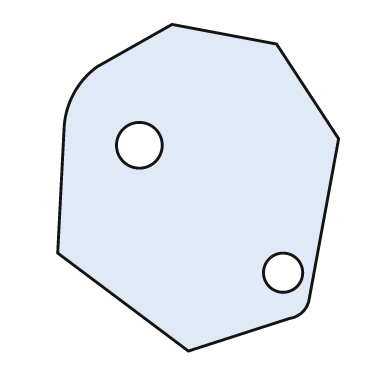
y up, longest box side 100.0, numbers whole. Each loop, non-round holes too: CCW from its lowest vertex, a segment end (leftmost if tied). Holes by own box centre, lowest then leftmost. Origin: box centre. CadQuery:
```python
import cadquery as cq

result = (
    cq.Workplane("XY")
    .moveTo(-3.0, -50.0)
    .lineTo(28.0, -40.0)
    .threePointArc((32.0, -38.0), (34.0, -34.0))
    .lineTo(43.0, 15.0)
    .lineTo(24.0, 44.0)
    .lineTo(-8.0, 50.0)
    .lineTo(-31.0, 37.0)
    .threePointArc((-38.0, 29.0), (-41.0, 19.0))
    .lineTo(-43.0, -20.0)
    .close()
    .moveTo(26.0, -26.0)
    .circle(6.0)
    .moveTo(-18.0, 13.0)
    .circle(7.0)
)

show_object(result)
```